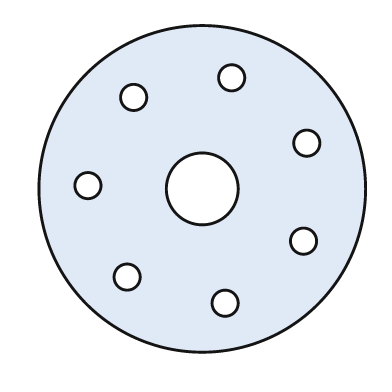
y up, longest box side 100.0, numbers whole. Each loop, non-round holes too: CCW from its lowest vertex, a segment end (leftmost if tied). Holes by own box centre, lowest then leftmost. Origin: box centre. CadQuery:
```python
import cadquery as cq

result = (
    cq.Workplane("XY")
    .moveTo(0.0, 0.0)
    .circle(50.0)
    .moveTo(7.0, -35.0)
    .circle(4.0)
    .moveTo(-23.0, -27.0)
    .circle(4.0)
    .moveTo(31.0, -16.0)
    .circle(4.0)
    .moveTo(0.0, 0.0)
    .circle(11.0)
    .moveTo(-35.0, 1.0)
    .circle(4.0)
    .moveTo(32.0, 14.0)
    .circle(4.0)
    .moveTo(-21.0, 28.0)
    .circle(4.0)
    .moveTo(9.0, 34.0)
    .circle(4.0)
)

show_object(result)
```